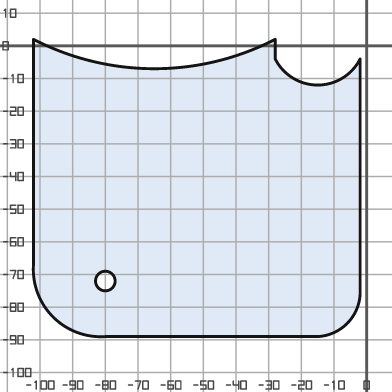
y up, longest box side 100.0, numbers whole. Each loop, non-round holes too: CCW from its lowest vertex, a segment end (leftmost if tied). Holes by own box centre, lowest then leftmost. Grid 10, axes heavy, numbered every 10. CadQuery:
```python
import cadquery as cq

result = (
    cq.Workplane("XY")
    .moveTo(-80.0, -89.0)
    .lineTo(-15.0, -89.0)
    .threePointArc((-6.0, -85.0), (-2.0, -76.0))
    .lineTo(-2.0, -4.0)
    .threePointArc((-15.0, -12.0), (-28.0, -4.0))
    .lineTo(-28.0, 2.0)
    .threePointArc((-65.0, -7.0), (-102.0, 2.0))
    .lineTo(-102.0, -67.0)
    .threePointArc((-96.0, -83.0), (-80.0, -89.0))
    .close()
    .moveTo(-80.0, -72.0)
    .circle(3.0)
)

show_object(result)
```